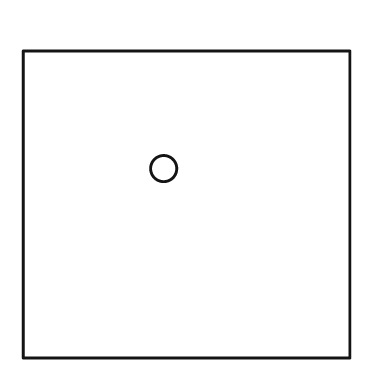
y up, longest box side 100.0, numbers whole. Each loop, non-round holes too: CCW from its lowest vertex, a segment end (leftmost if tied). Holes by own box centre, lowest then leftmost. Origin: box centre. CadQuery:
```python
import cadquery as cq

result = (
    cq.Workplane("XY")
    .moveTo(-50.0, -47.0)
    .lineTo(50.0, -47.0)
    .lineTo(50.0, 47.0)
    .lineTo(-50.0, 47.0)
    .close()
    .moveTo(-7.0, 11.0)
    .circle(4.0)
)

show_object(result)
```